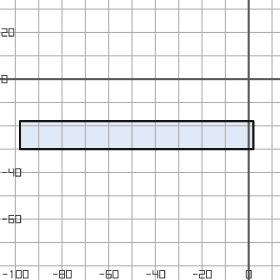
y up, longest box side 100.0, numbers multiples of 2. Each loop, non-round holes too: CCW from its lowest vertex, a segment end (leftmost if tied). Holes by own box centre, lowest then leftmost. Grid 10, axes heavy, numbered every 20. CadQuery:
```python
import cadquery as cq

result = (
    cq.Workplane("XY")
    .moveTo(-98.0, -30.0)
    .lineTo(2.0, -30.0)
    .lineTo(2.0, -18.0)
    .lineTo(-98.0, -18.0)
    .close()
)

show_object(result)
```